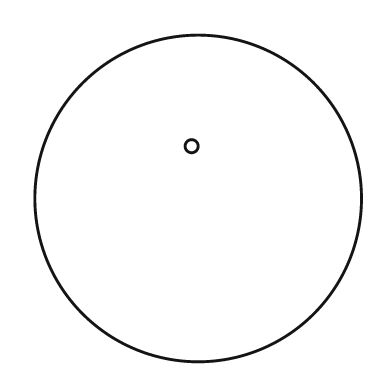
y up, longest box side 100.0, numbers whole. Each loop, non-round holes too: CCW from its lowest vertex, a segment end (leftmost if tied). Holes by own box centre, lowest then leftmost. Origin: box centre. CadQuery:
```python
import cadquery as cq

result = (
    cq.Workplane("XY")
    .moveTo(0.0, 0.0)
    .circle(50.0)
    .moveTo(-2.0, 16.0)
    .circle(2.0)
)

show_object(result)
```